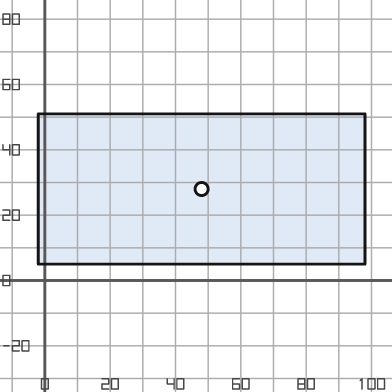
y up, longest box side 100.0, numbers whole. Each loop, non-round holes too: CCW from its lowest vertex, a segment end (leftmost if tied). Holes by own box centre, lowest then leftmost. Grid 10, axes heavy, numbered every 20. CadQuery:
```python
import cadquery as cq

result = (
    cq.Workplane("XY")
    .moveTo(-2.0, 5.0)
    .lineTo(98.0, 5.0)
    .lineTo(98.0, 51.0)
    .lineTo(-2.0, 51.0)
    .close()
    .moveTo(48.0, 28.0)
    .circle(2.0)
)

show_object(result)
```